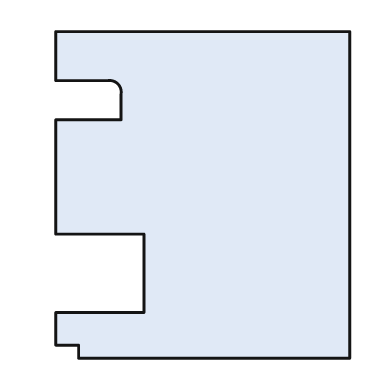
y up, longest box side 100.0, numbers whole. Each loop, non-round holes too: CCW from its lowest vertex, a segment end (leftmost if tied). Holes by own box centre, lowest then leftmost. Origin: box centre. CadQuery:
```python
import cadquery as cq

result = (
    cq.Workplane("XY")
    .moveTo(-38.0, -50.0)
    .lineTo(45.0, -50.0)
    .lineTo(45.0, 50.0)
    .lineTo(-45.0, 50.0)
    .lineTo(-45.0, 35.0)
    .lineTo(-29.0, 35.0)
    .threePointArc((-26.0, 34.0), (-25.0, 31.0))
    .lineTo(-25.0, 23.0)
    .lineTo(-45.0, 23.0)
    .lineTo(-45.0, -12.0)
    .lineTo(-18.0, -12.0)
    .lineTo(-18.0, -36.0)
    .lineTo(-45.0, -36.0)
    .lineTo(-45.0, -46.0)
    .lineTo(-38.0, -46.0)
    .close()
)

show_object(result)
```